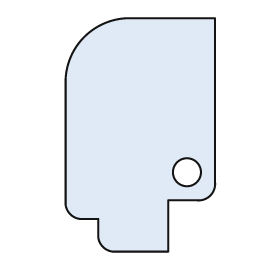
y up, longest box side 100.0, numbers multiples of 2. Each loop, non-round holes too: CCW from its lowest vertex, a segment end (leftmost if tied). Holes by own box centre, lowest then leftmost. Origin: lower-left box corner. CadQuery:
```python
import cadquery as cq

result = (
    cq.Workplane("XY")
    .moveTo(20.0, 0.0)
    .lineTo(44.0, 0.0)
    .lineTo(44.0, 22.0)
    .lineTo(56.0, 22.0)
    .threePointArc((62.0, 24.0), (64.0, 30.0))
    .lineTo(64.0, 100.0)
    .lineTo(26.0, 100.0)
    .threePointArc((8.0, 92.0), (0.0, 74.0))
    .lineTo(0.0, 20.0)
    .threePointArc((2.0, 16.0), (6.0, 14.0))
    .lineTo(14.0, 14.0)
    .lineTo(14.0, 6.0)
    .threePointArc((16.0, 2.0), (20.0, 0.0))
    .close()
    .moveTo(52.0, 34.0)
    .circle(6.0)
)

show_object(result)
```